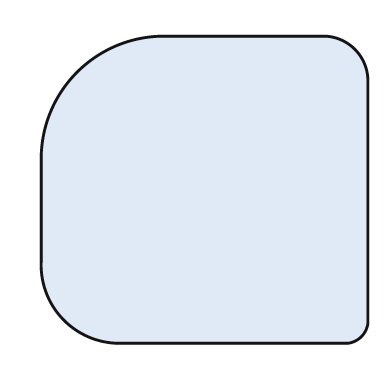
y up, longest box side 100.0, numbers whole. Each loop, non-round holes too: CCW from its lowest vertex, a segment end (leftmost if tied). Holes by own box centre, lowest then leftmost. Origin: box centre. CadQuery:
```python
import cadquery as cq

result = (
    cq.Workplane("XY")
    .moveTo(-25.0, -47.0)
    .lineTo(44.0, -47.0)
    .threePointArc((48.0, -45.0), (50.0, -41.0))
    .lineTo(50.0, 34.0)
    .threePointArc((46.0, 43.0), (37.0, 47.0))
    .lineTo(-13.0, 47.0)
    .threePointArc((-39.0, 36.0), (-50.0, 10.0))
    .lineTo(-50.0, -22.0)
    .threePointArc((-43.0, -40.0), (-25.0, -47.0))
    .close()
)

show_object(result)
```